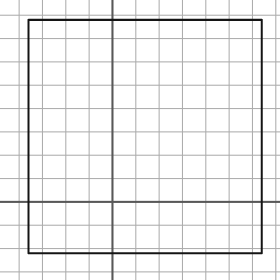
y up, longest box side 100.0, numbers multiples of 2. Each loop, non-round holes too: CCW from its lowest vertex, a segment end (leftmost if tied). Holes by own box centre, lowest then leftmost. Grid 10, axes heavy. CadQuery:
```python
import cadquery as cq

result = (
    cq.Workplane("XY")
    .moveTo(-36.0, -22.0)
    .lineTo(64.0, -22.0)
    .lineTo(64.0, 78.0)
    .lineTo(-36.0, 78.0)
    .close()
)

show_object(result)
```